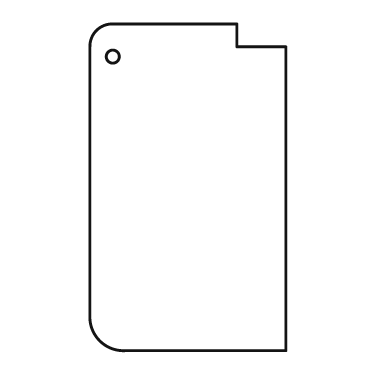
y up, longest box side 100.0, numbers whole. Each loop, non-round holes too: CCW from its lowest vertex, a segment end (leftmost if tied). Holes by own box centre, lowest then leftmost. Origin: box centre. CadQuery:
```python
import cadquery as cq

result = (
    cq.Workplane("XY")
    .moveTo(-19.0, -50.0)
    .lineTo(30.0, -50.0)
    .lineTo(30.0, 43.0)
    .lineTo(15.0, 43.0)
    .lineTo(15.0, 50.0)
    .lineTo(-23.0, 50.0)
    .threePointArc((-28.0, 48.0), (-30.0, 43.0))
    .lineTo(-30.0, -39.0)
    .threePointArc((-27.0, -47.0), (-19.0, -50.0))
    .close()
    .moveTo(-23.0, 40.0)
    .circle(2.0)
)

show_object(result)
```